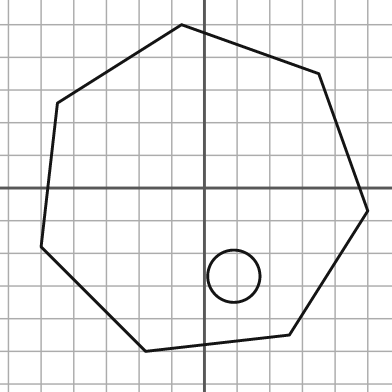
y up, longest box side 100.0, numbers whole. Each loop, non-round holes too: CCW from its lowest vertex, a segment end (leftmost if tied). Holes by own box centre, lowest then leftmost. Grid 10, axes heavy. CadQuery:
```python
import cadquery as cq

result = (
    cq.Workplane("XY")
    .moveTo(-18.0, -50.0)
    .lineTo(26.0, -45.0)
    .lineTo(50.0, -7.0)
    .lineTo(35.0, 35.0)
    .lineTo(-7.0, 50.0)
    .lineTo(-45.0, 26.0)
    .lineTo(-50.0, -18.0)
    .close()
    .moveTo(9.0, -27.0)
    .circle(8.0)
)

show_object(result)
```